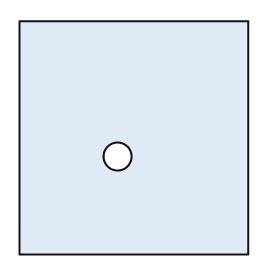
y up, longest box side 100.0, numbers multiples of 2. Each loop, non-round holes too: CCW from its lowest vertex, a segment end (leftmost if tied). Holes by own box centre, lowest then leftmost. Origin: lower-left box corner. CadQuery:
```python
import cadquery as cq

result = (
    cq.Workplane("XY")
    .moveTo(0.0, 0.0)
    .lineTo(98.0, 0.0)
    .lineTo(98.0, 100.0)
    .lineTo(0.0, 100.0)
    .close()
    .moveTo(42.0, 42.0)
    .circle(6.0)
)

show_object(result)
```